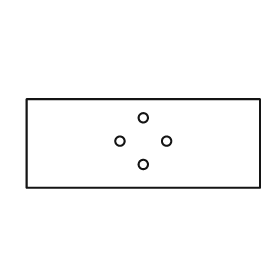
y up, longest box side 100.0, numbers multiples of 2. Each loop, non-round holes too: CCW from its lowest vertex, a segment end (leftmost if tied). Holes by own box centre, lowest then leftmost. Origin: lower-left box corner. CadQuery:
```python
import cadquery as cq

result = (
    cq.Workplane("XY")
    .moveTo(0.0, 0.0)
    .lineTo(100.0, 0.0)
    .lineTo(100.0, 38.0)
    .lineTo(0.0, 38.0)
    .close()
    .moveTo(50.0, 10.0)
    .circle(2.0)
    .moveTo(40.0, 20.0)
    .circle(2.0)
    .moveTo(60.0, 20.0)
    .circle(2.0)
    .moveTo(50.0, 30.0)
    .circle(2.0)
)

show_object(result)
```